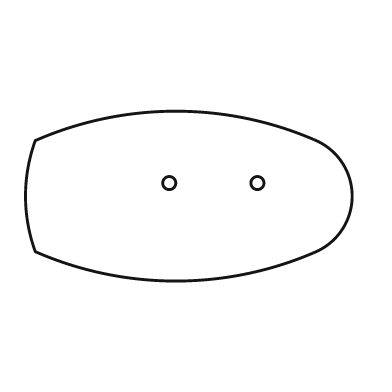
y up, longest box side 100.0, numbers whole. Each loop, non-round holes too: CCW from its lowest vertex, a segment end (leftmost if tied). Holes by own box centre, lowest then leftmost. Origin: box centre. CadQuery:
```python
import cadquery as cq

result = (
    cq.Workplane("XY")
    .moveTo(-47.0, -17.0)
    .threePointArc((-4.0, -26.0), (39.0, -17.0))
    .threePointArc((50.0, 0.0), (39.0, 17.0))
    .threePointArc((-4.0, 26.0), (-47.0, 17.0))
    .threePointArc((-50.0, 0.0), (-47.0, -17.0))
    .close()
    .moveTo(-6.0, 4.0)
    .circle(2.0)
    .moveTo(21.0, 4.0)
    .circle(2.0)
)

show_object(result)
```